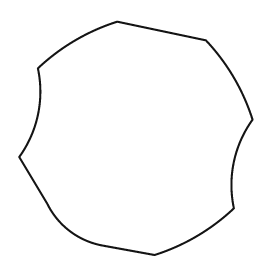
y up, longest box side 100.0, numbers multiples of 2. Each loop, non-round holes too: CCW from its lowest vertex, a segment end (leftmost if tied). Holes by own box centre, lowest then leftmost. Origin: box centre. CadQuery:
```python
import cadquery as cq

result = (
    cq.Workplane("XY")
    .moveTo(8.0, -50.0)
    .threePointArc((26.0, -42.0), (42.0, -30.0))
    .threePointArc((42.0, -10.0), (50.0, 8.0))
    .threePointArc((42.0, 26.0), (30.0, 42.0))
    .lineTo(-8.0, 50.0)
    .threePointArc((-26.0, 42.0), (-42.0, 30.0))
    .threePointArc((-42.0, 10.0), (-50.0, -8.0))
    .lineTo(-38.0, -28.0)
    .threePointArc((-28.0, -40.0), (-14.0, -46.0))
    .close()
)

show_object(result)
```